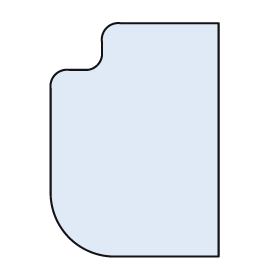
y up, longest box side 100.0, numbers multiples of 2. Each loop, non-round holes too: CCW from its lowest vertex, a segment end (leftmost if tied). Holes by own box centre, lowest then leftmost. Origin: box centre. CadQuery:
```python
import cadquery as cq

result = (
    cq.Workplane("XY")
    .moveTo(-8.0, -50.0)
    .lineTo(36.0, -50.0)
    .lineTo(36.0, 50.0)
    .lineTo(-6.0, 50.0)
    .threePointArc((-12.0, 48.0), (-14.0, 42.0))
    .lineTo(-14.0, 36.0)
    .threePointArc((-16.0, 32.0), (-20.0, 30.0))
    .lineTo(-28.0, 30.0)
    .threePointArc((-34.0, 28.0), (-36.0, 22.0))
    .lineTo(-36.0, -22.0)
    .threePointArc((-28.0, -42.0), (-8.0, -50.0))
    .close()
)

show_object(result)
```